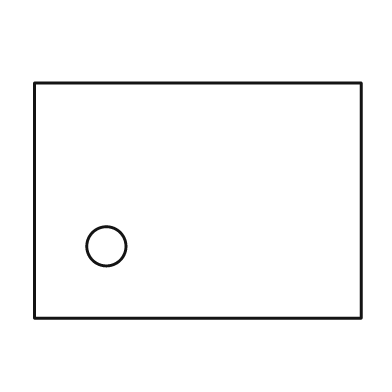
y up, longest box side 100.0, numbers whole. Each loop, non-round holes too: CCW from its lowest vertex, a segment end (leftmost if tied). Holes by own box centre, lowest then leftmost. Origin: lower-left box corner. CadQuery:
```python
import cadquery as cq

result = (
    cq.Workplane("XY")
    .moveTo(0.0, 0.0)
    .lineTo(100.0, 0.0)
    .lineTo(100.0, 72.0)
    .lineTo(0.0, 72.0)
    .close()
    .moveTo(22.0, 22.0)
    .circle(6.0)
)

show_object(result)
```